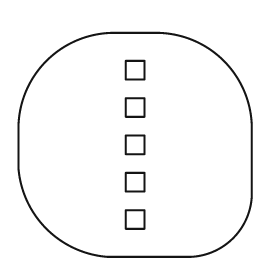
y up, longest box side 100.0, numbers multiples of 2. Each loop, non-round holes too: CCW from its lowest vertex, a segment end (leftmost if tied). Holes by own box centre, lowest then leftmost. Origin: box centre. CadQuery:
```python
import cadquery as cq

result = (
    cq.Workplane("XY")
    .moveTo(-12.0, -48.0)
    .lineTo(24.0, -48.0)
    .threePointArc((42.0, -40.0), (50.0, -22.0))
    .lineTo(50.0, 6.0)
    .threePointArc((38.0, 36.0), (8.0, 48.0))
    .lineTo(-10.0, 48.0)
    .threePointArc((-38.0, 36.0), (-50.0, 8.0))
    .lineTo(-50.0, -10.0)
    .threePointArc((-38.0, -36.0), (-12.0, -48.0))
    .close()
    .moveTo(-4.0, -36.0)
    .lineTo(4.0, -36.0)
    .lineTo(4.0, -28.0)
    .lineTo(-4.0, -28.0)
    .close()
    .moveTo(-4.0, -20.0)
    .lineTo(4.0, -20.0)
    .lineTo(4.0, -12.0)
    .lineTo(-4.0, -12.0)
    .close()
    .moveTo(-4.0, -4.0)
    .lineTo(4.0, -4.0)
    .lineTo(4.0, 4.0)
    .lineTo(-4.0, 4.0)
    .close()
    .moveTo(-4.0, 12.0)
    .lineTo(4.0, 12.0)
    .lineTo(4.0, 20.0)
    .lineTo(-4.0, 20.0)
    .close()
    .moveTo(-4.0, 28.0)
    .lineTo(4.0, 28.0)
    .lineTo(4.0, 36.0)
    .lineTo(-4.0, 36.0)
    .close()
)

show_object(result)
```